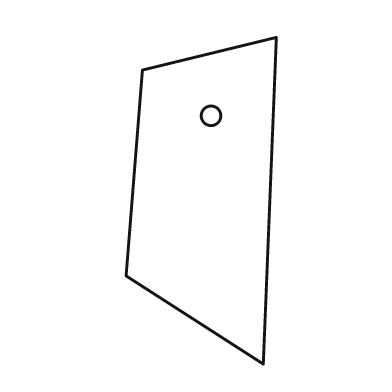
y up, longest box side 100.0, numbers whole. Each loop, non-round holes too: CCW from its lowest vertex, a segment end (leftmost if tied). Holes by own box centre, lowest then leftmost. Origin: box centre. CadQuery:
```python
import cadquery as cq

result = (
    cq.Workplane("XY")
    .moveTo(19.0, -50.0)
    .lineTo(23.0, 50.0)
    .lineTo(-18.0, 40.0)
    .lineTo(-23.0, -23.0)
    .close()
    .moveTo(3.0, 26.0)
    .circle(3.0)
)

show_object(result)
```